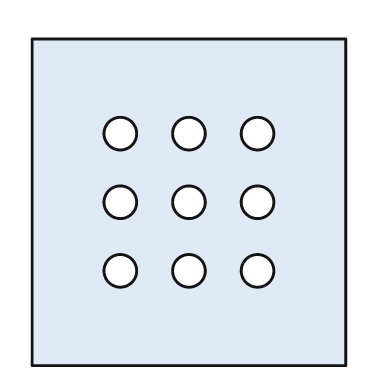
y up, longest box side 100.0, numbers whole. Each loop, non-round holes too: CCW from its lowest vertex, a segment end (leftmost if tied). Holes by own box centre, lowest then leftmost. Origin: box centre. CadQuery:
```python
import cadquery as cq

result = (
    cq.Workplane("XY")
    .moveTo(-48.0, -50.0)
    .lineTo(48.0, -50.0)
    .lineTo(48.0, 50.0)
    .lineTo(-48.0, 50.0)
    .close()
    .moveTo(-21.0, -21.0)
    .circle(5.0)
    .moveTo(0.0, -21.0)
    .circle(5.0)
    .moveTo(21.0, -21.0)
    .circle(5.0)
    .moveTo(-21.0, 0.0)
    .circle(5.0)
    .moveTo(0.0, 0.0)
    .circle(5.0)
    .moveTo(21.0, 0.0)
    .circle(5.0)
    .moveTo(-21.0, 21.0)
    .circle(5.0)
    .moveTo(0.0, 21.0)
    .circle(5.0)
    .moveTo(21.0, 21.0)
    .circle(5.0)
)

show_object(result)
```